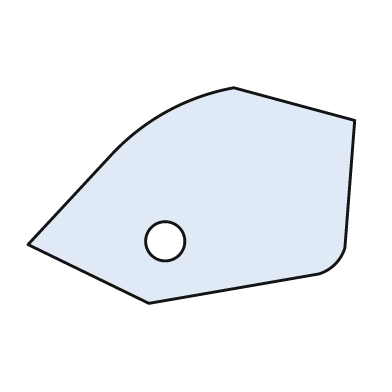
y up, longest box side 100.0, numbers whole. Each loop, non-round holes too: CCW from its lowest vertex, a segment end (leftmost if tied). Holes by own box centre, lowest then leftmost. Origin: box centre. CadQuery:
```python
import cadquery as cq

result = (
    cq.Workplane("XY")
    .moveTo(-13.0, -33.0)
    .lineTo(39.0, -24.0)
    .threePointArc((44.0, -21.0), (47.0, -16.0))
    .lineTo(50.0, 23.0)
    .lineTo(13.0, 33.0)
    .threePointArc((-7.0, 26.0), (-24.0, 13.0))
    .lineTo(-50.0, -15.0)
    .close()
    .moveTo(-8.0, -14.0)
    .circle(6.0)
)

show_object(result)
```